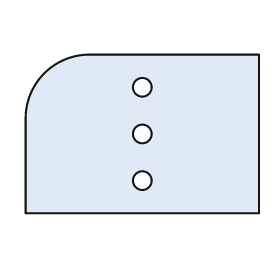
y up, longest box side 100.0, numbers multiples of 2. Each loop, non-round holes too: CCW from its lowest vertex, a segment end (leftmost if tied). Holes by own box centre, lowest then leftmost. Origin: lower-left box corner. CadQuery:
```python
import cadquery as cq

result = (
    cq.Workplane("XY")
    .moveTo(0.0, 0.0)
    .lineTo(100.0, 0.0)
    .lineTo(100.0, 68.0)
    .lineTo(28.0, 68.0)
    .threePointArc((8.0, 60.0), (0.0, 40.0))
    .close()
    .moveTo(50.0, 14.0)
    .circle(4.0)
    .moveTo(50.0, 34.0)
    .circle(4.0)
    .moveTo(50.0, 54.0)
    .circle(4.0)
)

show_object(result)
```